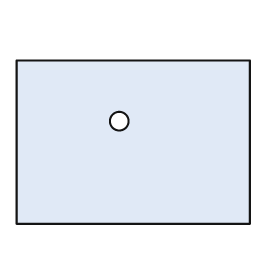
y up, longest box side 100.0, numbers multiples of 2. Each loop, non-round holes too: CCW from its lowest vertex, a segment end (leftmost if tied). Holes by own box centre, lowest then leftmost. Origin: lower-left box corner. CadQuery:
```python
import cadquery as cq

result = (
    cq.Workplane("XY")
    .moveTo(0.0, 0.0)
    .lineTo(100.0, 0.0)
    .lineTo(100.0, 70.0)
    .lineTo(0.0, 70.0)
    .close()
    .moveTo(44.0, 44.0)
    .circle(4.0)
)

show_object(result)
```